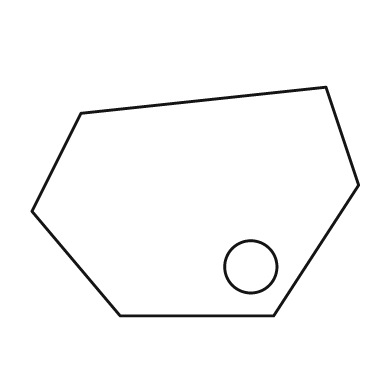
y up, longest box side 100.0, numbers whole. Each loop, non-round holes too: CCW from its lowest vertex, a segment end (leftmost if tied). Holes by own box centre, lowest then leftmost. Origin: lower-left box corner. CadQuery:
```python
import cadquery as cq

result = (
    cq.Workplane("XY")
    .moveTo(27.0, 0.0)
    .lineTo(74.0, 0.0)
    .lineTo(100.0, 40.0)
    .lineTo(90.0, 70.0)
    .lineTo(15.0, 62.0)
    .lineTo(0.0, 32.0)
    .close()
    .moveTo(67.0, 15.0)
    .circle(8.0)
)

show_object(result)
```